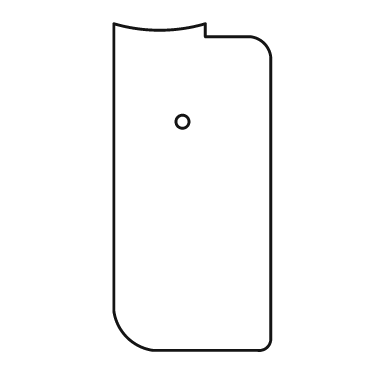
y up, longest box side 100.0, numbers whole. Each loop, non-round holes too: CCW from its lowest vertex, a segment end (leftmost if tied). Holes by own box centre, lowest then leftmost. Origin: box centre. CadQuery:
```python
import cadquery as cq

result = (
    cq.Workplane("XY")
    .moveTo(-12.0, -50.0)
    .lineTo(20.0, -50.0)
    .threePointArc((23.0, -49.0), (24.0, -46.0))
    .lineTo(24.0, 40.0)
    .threePointArc((22.0, 44.0), (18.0, 46.0))
    .lineTo(4.0, 46.0)
    .lineTo(4.0, 50.0)
    .threePointArc((-10.0, 48.0), (-24.0, 50.0))
    .lineTo(-24.0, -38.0)
    .threePointArc((-20.0, -46.0), (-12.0, -50.0))
    .close()
    .moveTo(-3.0, 20.0)
    .circle(2.0)
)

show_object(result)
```